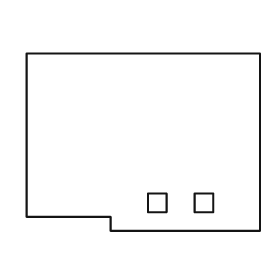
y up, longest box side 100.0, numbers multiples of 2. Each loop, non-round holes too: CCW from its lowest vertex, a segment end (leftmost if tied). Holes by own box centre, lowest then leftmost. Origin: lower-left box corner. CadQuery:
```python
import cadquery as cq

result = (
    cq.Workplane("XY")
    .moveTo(36.0, 0.0)
    .lineTo(100.0, 0.0)
    .lineTo(100.0, 76.0)
    .lineTo(0.0, 76.0)
    .lineTo(0.0, 6.0)
    .lineTo(36.0, 6.0)
    .close()
    .moveTo(52.0, 8.0)
    .lineTo(60.0, 8.0)
    .lineTo(60.0, 16.0)
    .lineTo(52.0, 16.0)
    .close()
    .moveTo(72.0, 8.0)
    .lineTo(80.0, 8.0)
    .lineTo(80.0, 16.0)
    .lineTo(72.0, 16.0)
    .close()
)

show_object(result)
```